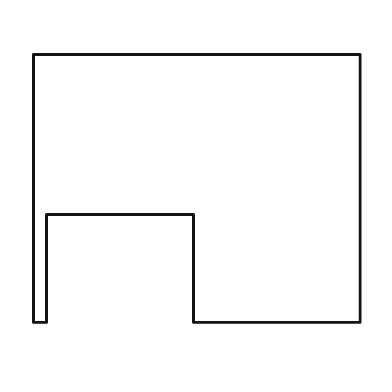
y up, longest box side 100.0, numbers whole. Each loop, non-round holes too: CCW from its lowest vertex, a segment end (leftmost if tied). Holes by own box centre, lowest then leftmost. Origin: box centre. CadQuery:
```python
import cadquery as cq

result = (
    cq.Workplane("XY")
    .moveTo(-50.0, -41.0)
    .lineTo(-46.0, -41.0)
    .lineTo(-46.0, -8.0)
    .lineTo(-1.0, -8.0)
    .lineTo(-1.0, -41.0)
    .lineTo(50.0, -41.0)
    .lineTo(50.0, 41.0)
    .lineTo(-50.0, 41.0)
    .close()
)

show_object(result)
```